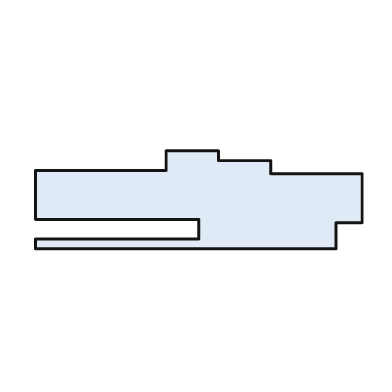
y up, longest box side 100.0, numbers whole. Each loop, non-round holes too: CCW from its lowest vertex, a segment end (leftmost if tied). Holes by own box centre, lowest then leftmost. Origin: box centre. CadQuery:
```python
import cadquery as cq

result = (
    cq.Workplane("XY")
    .moveTo(-50.0, -15.0)
    .lineTo(42.0, -15.0)
    .lineTo(42.0, -7.0)
    .lineTo(50.0, -7.0)
    .lineTo(50.0, 8.0)
    .lineTo(22.0, 8.0)
    .lineTo(22.0, 12.0)
    .lineTo(6.0, 12.0)
    .lineTo(6.0, 15.0)
    .lineTo(-10.0, 15.0)
    .lineTo(-10.0, 9.0)
    .lineTo(-50.0, 9.0)
    .lineTo(-50.0, -6.0)
    .lineTo(0.0, -6.0)
    .lineTo(0.0, -12.0)
    .lineTo(-50.0, -12.0)
    .close()
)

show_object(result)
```